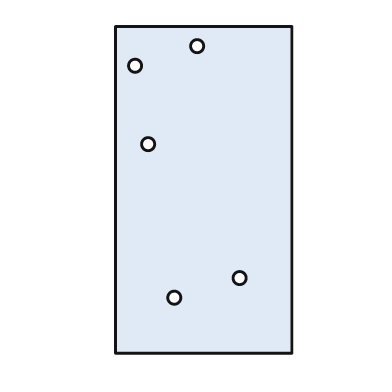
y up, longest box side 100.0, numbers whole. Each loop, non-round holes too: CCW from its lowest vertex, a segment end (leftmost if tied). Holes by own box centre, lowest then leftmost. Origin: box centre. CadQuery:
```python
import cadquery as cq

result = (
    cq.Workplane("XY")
    .moveTo(-27.0, -50.0)
    .lineTo(27.0, -50.0)
    .lineTo(27.0, 50.0)
    .lineTo(-27.0, 50.0)
    .close()
    .moveTo(-9.0, -33.0)
    .circle(2.0)
    .moveTo(11.0, -27.0)
    .circle(2.0)
    .moveTo(-17.0, 14.0)
    .circle(2.0)
    .moveTo(-21.0, 38.0)
    .circle(2.0)
    .moveTo(-2.0, 44.0)
    .circle(2.0)
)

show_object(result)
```